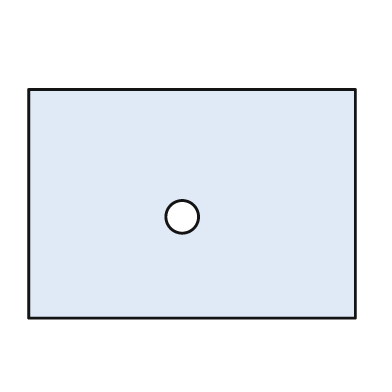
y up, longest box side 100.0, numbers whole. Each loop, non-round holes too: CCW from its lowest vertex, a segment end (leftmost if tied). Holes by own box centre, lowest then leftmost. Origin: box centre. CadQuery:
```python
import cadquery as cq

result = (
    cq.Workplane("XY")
    .moveTo(-50.0, -35.0)
    .lineTo(50.0, -35.0)
    .lineTo(50.0, 35.0)
    .lineTo(-50.0, 35.0)
    .close()
    .moveTo(-3.0, -4.0)
    .circle(5.0)
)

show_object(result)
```